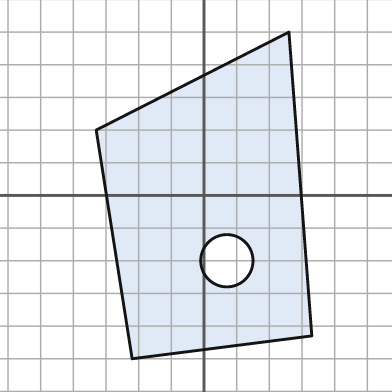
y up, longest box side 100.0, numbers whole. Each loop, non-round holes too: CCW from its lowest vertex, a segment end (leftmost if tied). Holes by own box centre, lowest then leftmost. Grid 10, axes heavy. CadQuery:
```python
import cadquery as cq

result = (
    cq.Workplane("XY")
    .moveTo(-22.0, -50.0)
    .lineTo(33.0, -43.0)
    .lineTo(26.0, 50.0)
    .lineTo(-33.0, 20.0)
    .close()
    .moveTo(7.0, -20.0)
    .circle(8.0)
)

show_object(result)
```